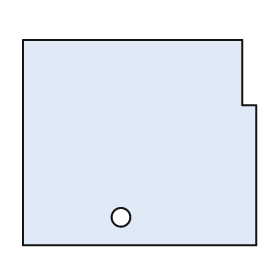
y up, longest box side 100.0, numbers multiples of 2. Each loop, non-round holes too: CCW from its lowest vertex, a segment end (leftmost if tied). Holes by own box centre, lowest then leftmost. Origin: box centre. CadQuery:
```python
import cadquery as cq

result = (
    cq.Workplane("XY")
    .moveTo(-50.0, -44.0)
    .lineTo(50.0, -44.0)
    .lineTo(50.0, 16.0)
    .lineTo(44.0, 16.0)
    .lineTo(44.0, 44.0)
    .lineTo(-50.0, 44.0)
    .close()
    .moveTo(-8.0, -32.0)
    .circle(4.0)
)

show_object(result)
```